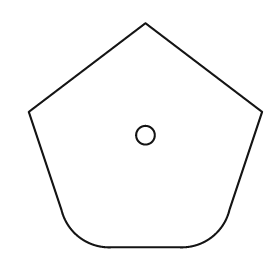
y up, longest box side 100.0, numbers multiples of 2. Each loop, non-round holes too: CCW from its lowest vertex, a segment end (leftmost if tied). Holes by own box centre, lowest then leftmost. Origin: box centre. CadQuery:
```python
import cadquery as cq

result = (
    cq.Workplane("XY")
    .moveTo(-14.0, -48.0)
    .lineTo(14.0, -48.0)
    .threePointArc((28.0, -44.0), (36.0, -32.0))
    .lineTo(50.0, 10.0)
    .lineTo(0.0, 48.0)
    .lineTo(-50.0, 10.0)
    .lineTo(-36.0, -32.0)
    .threePointArc((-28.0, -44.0), (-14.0, -48.0))
    .close()
    .moveTo(0.0, 0.0)
    .circle(4.0)
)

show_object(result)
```